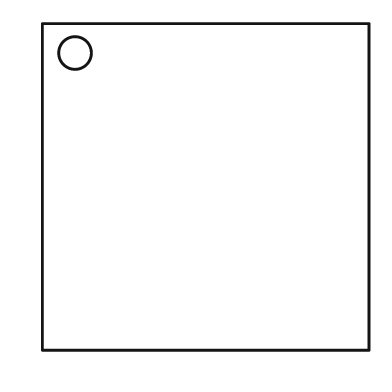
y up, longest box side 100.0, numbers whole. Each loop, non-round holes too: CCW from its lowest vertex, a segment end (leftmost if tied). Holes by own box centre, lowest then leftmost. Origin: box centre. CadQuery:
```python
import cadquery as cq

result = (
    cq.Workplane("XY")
    .moveTo(-50.0, -50.0)
    .lineTo(50.0, -50.0)
    .lineTo(50.0, 50.0)
    .lineTo(-50.0, 50.0)
    .close()
    .moveTo(-40.0, 41.0)
    .circle(5.0)
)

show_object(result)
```